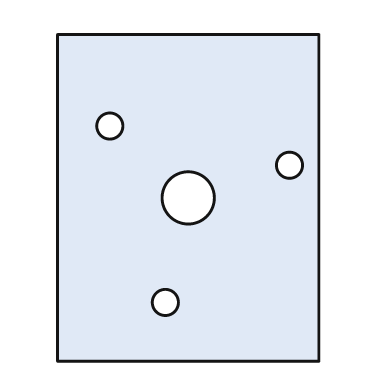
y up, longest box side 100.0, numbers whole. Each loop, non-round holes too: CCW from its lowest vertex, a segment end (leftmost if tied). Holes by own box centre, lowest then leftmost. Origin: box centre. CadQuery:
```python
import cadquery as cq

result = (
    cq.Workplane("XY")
    .moveTo(-40.0, -50.0)
    .lineTo(40.0, -50.0)
    .lineTo(40.0, 50.0)
    .lineTo(-40.0, 50.0)
    .close()
    .moveTo(-7.0, -32.0)
    .circle(4.0)
    .moveTo(0.0, 0.0)
    .circle(8.0)
    .moveTo(31.0, 10.0)
    .circle(4.0)
    .moveTo(-24.0, 22.0)
    .circle(4.0)
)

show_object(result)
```